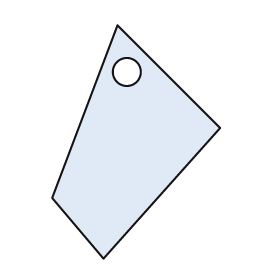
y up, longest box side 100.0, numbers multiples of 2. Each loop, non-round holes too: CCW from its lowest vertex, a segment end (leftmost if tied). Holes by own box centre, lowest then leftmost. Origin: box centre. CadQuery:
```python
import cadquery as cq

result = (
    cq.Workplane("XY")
    .moveTo(-14.0, -50.0)
    .lineTo(36.0, 6.0)
    .lineTo(-8.0, 50.0)
    .lineTo(-36.0, -24.0)
    .close()
    .moveTo(-4.0, 30.0)
    .circle(6.0)
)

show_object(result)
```